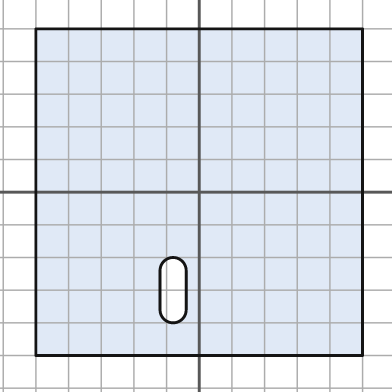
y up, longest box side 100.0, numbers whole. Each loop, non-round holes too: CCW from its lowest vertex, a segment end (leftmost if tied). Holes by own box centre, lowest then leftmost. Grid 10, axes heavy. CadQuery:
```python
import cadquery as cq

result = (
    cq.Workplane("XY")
    .moveTo(-50.0, -50.0)
    .lineTo(50.0, -50.0)
    .lineTo(50.0, 50.0)
    .lineTo(-50.0, 50.0)
    .close()
    .moveTo(-12.0, -36.0)
    .threePointArc((-8.0, -40.0), (-4.0, -36.0))
    .lineTo(-4.0, -24.0)
    .threePointArc((-8.0, -20.0), (-12.0, -24.0))
    .close()
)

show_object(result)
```